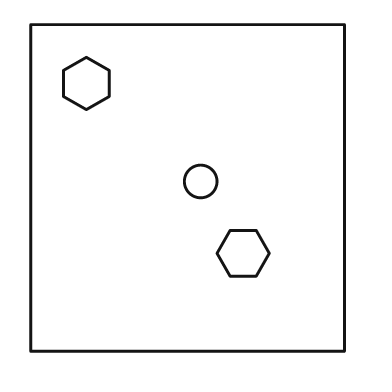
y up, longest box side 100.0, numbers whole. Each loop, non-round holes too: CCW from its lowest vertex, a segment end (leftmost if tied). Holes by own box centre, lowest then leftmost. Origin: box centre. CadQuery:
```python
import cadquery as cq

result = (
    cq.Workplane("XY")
    .moveTo(-48.0, -50.0)
    .lineTo(48.0, -50.0)
    .lineTo(48.0, 50.0)
    .lineTo(-48.0, 50.0)
    .close()
    .moveTo(13.0, -27.0)
    .lineTo(21.0, -27.0)
    .lineTo(25.0, -20.0)
    .lineTo(21.0, -13.0)
    .lineTo(13.0, -13.0)
    .lineTo(9.0, -20.0)
    .close()
    .moveTo(4.0, 2.0)
    .circle(5.0)
    .moveTo(-31.0, 24.0)
    .lineTo(-24.0, 28.0)
    .lineTo(-24.0, 36.0)
    .lineTo(-31.0, 40.0)
    .lineTo(-38.0, 36.0)
    .lineTo(-38.0, 28.0)
    .close()
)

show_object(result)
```